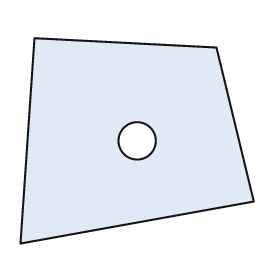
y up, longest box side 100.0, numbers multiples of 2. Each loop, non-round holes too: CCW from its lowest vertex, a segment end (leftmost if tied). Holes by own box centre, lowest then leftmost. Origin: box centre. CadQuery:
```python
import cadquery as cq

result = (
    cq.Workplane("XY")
    .moveTo(-50.0, -44.0)
    .lineTo(50.0, -26.0)
    .lineTo(34.0, 40.0)
    .lineTo(-44.0, 44.0)
    .close()
    .moveTo(0.0, 0.0)
    .circle(8.0)
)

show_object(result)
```